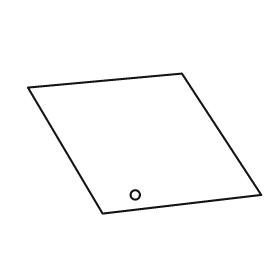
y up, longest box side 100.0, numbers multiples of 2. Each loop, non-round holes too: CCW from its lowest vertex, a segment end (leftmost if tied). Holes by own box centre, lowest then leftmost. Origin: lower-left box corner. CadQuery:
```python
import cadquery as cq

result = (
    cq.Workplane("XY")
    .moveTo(32.0, 0.0)
    .lineTo(100.0, 8.0)
    .lineTo(66.0, 60.0)
    .lineTo(0.0, 54.0)
    .close()
    .moveTo(46.0, 8.0)
    .circle(2.0)
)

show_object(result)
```